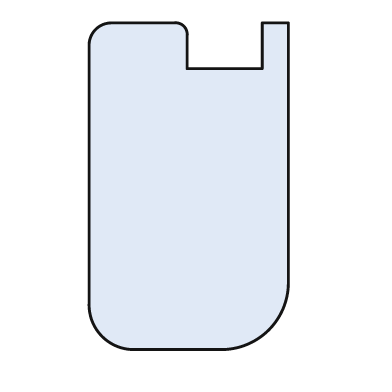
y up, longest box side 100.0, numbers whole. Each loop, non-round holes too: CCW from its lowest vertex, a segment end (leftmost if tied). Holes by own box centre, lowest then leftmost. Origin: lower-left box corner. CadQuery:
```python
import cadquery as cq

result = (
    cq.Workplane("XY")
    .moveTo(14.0, 0.0)
    .lineTo(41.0, 0.0)
    .threePointArc((55.0, 6.0), (61.0, 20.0))
    .lineTo(61.0, 100.0)
    .lineTo(53.0, 100.0)
    .lineTo(53.0, 86.0)
    .lineTo(30.0, 86.0)
    .lineTo(30.0, 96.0)
    .threePointArc((29.0, 99.0), (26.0, 100.0))
    .lineTo(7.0, 100.0)
    .threePointArc((2.0, 98.0), (0.0, 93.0))
    .lineTo(0.0, 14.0)
    .threePointArc((4.0, 4.0), (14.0, 0.0))
    .close()
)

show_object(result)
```